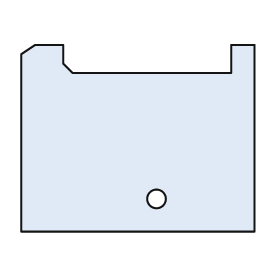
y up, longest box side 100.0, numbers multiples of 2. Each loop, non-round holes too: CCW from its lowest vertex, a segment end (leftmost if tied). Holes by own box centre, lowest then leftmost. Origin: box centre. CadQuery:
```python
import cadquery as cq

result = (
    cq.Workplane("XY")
    .moveTo(-50.0, -40.0)
    .lineTo(50.0, -40.0)
    .lineTo(50.0, 40.0)
    .lineTo(40.0, 40.0)
    .lineTo(40.0, 28.0)
    .lineTo(-28.0, 28.0)
    .lineTo(-32.0, 32.0)
    .lineTo(-32.0, 40.0)
    .lineTo(-44.0, 40.0)
    .lineTo(-50.0, 36.0)
    .close()
    .moveTo(8.0, -26.0)
    .circle(4.0)
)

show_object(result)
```